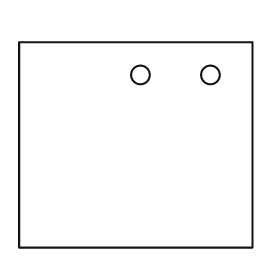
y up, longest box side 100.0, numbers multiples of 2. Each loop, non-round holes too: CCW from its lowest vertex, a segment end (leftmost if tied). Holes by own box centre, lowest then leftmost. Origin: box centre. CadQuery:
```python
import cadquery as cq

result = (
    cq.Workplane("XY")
    .moveTo(-50.0, -44.0)
    .lineTo(50.0, -44.0)
    .lineTo(50.0, 44.0)
    .lineTo(-50.0, 44.0)
    .close()
    .moveTo(2.0, 30.0)
    .circle(4.0)
    .moveTo(32.0, 30.0)
    .circle(4.0)
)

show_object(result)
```